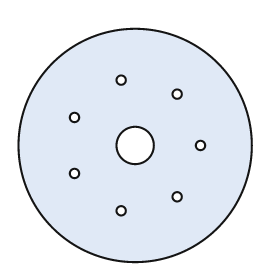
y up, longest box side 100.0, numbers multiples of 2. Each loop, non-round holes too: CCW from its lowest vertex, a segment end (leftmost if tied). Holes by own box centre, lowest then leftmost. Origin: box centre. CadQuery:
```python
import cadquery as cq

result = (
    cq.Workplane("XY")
    .moveTo(0.0, 0.0)
    .circle(50.0)
    .moveTo(-6.0, -28.0)
    .circle(2.0)
    .moveTo(18.0, -22.0)
    .circle(2.0)
    .moveTo(-26.0, -12.0)
    .circle(2.0)
    .moveTo(0.0, 0.0)
    .circle(8.0)
    .moveTo(28.0, 0.0)
    .circle(2.0)
    .moveTo(-26.0, 12.0)
    .circle(2.0)
    .moveTo(18.0, 22.0)
    .circle(2.0)
    .moveTo(-6.0, 28.0)
    .circle(2.0)
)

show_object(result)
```